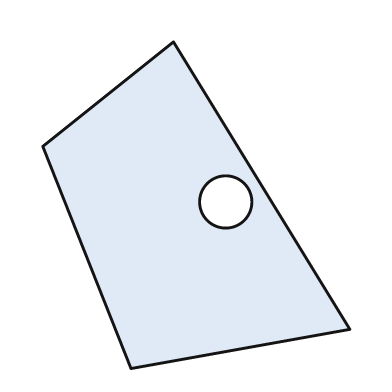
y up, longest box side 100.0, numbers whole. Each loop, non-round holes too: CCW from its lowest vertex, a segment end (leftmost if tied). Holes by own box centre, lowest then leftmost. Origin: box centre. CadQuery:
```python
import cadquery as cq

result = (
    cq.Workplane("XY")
    .moveTo(-20.0, -50.0)
    .lineTo(47.0, -38.0)
    .lineTo(-7.0, 50.0)
    .lineTo(-47.0, 18.0)
    .close()
    .moveTo(9.0, 1.0)
    .circle(8.0)
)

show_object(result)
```